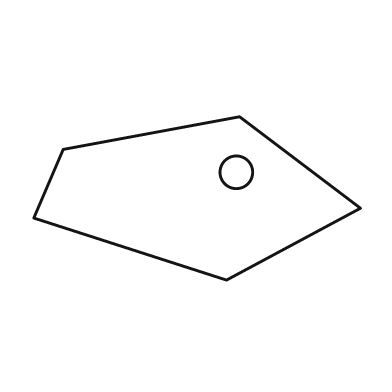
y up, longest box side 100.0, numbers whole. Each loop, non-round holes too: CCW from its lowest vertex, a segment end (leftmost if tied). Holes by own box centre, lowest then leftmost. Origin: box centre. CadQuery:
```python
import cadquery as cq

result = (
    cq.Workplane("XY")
    .moveTo(9.0, -25.0)
    .lineTo(50.0, -3.0)
    .lineTo(13.0, 25.0)
    .lineTo(-41.0, 15.0)
    .lineTo(-50.0, -6.0)
    .close()
    .moveTo(12.0, 8.0)
    .circle(5.0)
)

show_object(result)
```